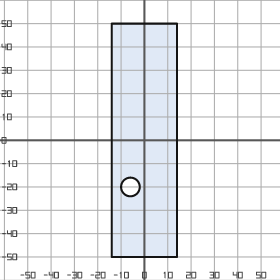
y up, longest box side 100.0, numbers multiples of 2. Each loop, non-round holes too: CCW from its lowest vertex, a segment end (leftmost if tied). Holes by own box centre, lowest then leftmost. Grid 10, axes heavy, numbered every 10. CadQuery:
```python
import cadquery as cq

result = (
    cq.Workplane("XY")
    .moveTo(-14.0, -50.0)
    .lineTo(14.0, -50.0)
    .lineTo(14.0, 50.0)
    .lineTo(-14.0, 50.0)
    .close()
    .moveTo(-6.0, -20.0)
    .circle(4.0)
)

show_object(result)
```